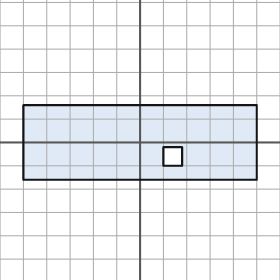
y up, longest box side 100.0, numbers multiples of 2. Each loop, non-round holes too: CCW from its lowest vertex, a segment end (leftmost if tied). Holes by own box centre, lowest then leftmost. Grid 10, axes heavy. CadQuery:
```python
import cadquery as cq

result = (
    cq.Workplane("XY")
    .moveTo(-50.0, -16.0)
    .lineTo(50.0, -16.0)
    .lineTo(50.0, 16.0)
    .lineTo(-50.0, 16.0)
    .close()
    .moveTo(10.0, -10.0)
    .lineTo(18.0, -10.0)
    .lineTo(18.0, -2.0)
    .lineTo(10.0, -2.0)
    .close()
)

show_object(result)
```